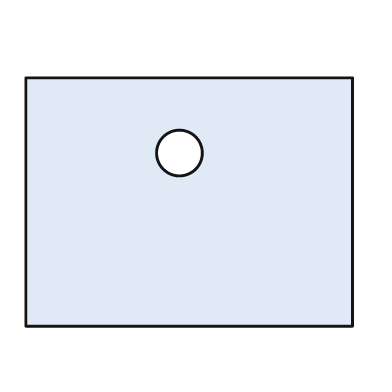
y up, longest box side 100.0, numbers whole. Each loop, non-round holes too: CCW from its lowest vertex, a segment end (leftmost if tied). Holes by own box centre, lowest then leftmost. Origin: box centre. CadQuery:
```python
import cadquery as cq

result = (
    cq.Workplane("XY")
    .moveTo(-50.0, -38.0)
    .lineTo(50.0, -38.0)
    .lineTo(50.0, 38.0)
    .lineTo(-50.0, 38.0)
    .close()
    .moveTo(-3.0, 15.0)
    .circle(7.0)
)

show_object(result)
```